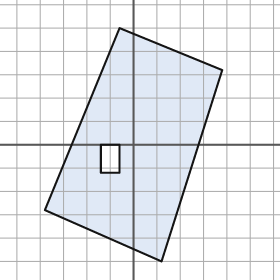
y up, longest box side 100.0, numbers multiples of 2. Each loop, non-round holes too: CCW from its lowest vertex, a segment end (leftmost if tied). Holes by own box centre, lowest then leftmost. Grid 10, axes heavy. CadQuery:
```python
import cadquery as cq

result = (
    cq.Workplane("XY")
    .moveTo(12.0, -50.0)
    .lineTo(38.0, 32.0)
    .lineTo(-6.0, 50.0)
    .lineTo(-38.0, -28.0)
    .close()
    .moveTo(-14.0, -12.0)
    .lineTo(-6.0, -12.0)
    .lineTo(-6.0, 0.0)
    .lineTo(-14.0, 0.0)
    .close()
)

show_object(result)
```